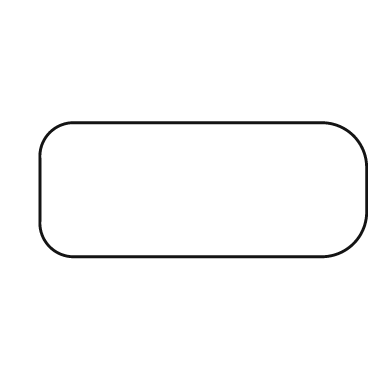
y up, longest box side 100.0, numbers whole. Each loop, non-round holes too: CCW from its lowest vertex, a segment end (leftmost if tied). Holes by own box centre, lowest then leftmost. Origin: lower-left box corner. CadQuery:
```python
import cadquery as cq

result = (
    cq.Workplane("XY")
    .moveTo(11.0, 0.0)
    .lineTo(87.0, 0.0)
    .threePointArc((96.0, 4.0), (100.0, 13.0))
    .lineTo(100.0, 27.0)
    .threePointArc((96.0, 37.0), (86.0, 41.0))
    .lineTo(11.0, 41.0)
    .threePointArc((3.0, 38.0), (0.0, 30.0))
    .lineTo(0.0, 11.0)
    .threePointArc((3.0, 3.0), (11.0, 0.0))
    .close()
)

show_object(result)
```